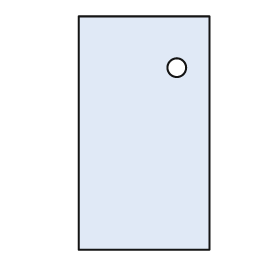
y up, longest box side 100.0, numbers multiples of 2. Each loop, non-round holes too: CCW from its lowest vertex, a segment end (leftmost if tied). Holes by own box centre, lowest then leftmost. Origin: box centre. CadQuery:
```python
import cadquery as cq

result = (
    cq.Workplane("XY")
    .moveTo(-28.0, -50.0)
    .lineTo(28.0, -50.0)
    .lineTo(28.0, 50.0)
    .lineTo(-28.0, 50.0)
    .close()
    .moveTo(14.0, 28.0)
    .circle(4.0)
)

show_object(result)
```